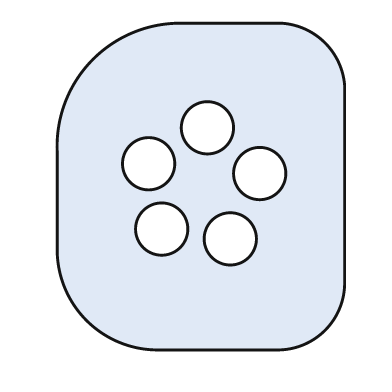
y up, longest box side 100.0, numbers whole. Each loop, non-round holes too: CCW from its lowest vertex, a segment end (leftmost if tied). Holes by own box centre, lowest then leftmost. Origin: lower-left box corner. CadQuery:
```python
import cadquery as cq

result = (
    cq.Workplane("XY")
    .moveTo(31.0, 0.0)
    .lineTo(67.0, 0.0)
    .threePointArc((82.0, 6.0), (88.0, 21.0))
    .lineTo(88.0, 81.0)
    .threePointArc((82.0, 94.0), (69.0, 100.0))
    .lineTo(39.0, 100.0)
    .threePointArc((11.0, 89.0), (0.0, 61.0))
    .lineTo(0.0, 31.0)
    .threePointArc((9.0, 9.0), (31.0, 0.0))
    .close()
    .moveTo(53.0, 34.0)
    .circle(8.0)
    .moveTo(32.0, 37.0)
    .circle(8.0)
    .moveTo(62.0, 54.0)
    .circle(8.0)
    .moveTo(28.0, 57.0)
    .circle(8.0)
    .moveTo(46.0, 68.0)
    .circle(8.0)
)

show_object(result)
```